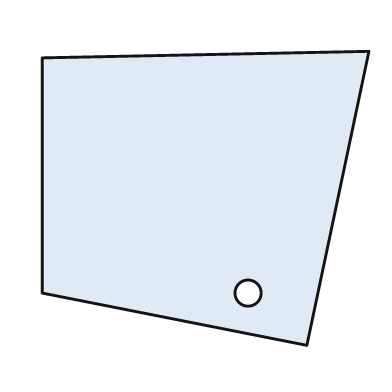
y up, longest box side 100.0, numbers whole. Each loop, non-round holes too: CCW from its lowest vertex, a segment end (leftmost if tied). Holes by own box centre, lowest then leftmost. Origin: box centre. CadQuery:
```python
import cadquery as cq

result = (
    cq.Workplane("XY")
    .moveTo(31.0, -45.0)
    .lineTo(50.0, 45.0)
    .lineTo(-50.0, 43.0)
    .lineTo(-50.0, -29.0)
    .close()
    .moveTo(13.0, -29.0)
    .circle(4.0)
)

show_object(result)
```